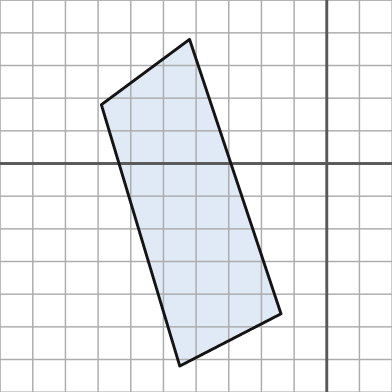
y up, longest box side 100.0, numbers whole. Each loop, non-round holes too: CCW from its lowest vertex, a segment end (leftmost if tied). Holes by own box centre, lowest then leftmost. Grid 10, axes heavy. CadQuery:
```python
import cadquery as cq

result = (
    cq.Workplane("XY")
    .moveTo(-45.0, -62.0)
    .lineTo(-14.0, -46.0)
    .lineTo(-42.0, 38.0)
    .lineTo(-69.0, 18.0)
    .close()
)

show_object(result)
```